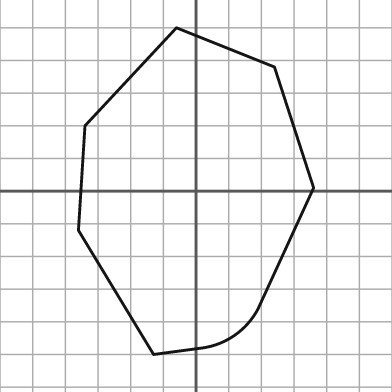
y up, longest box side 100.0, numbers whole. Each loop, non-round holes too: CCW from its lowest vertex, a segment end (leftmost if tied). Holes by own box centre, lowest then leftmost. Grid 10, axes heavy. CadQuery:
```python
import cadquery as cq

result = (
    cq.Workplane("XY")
    .moveTo(-13.0, -50.0)
    .lineTo(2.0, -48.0)
    .threePointArc((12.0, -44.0), (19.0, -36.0))
    .lineTo(36.0, 1.0)
    .lineTo(24.0, 38.0)
    .lineTo(-6.0, 50.0)
    .lineTo(-34.0, 20.0)
    .lineTo(-36.0, -12.0)
    .close()
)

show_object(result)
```